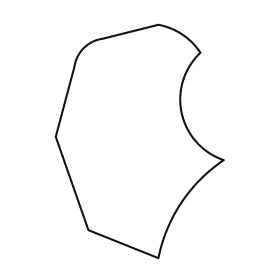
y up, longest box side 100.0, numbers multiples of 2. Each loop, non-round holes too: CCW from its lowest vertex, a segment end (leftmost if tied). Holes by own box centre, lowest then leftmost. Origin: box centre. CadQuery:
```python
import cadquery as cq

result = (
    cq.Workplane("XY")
    .moveTo(8.0, -50.0)
    .threePointArc((18.0, -26.0), (36.0, -8.0))
    .threePointArc((18.0, 12.0), (26.0, 38.0))
    .threePointArc((18.0, 46.0), (8.0, 50.0))
    .lineTo(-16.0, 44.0)
    .threePointArc((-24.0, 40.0), (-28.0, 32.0))
    .lineTo(-36.0, 2.0)
    .lineTo(-22.0, -38.0)
    .close()
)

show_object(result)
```